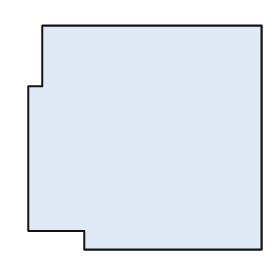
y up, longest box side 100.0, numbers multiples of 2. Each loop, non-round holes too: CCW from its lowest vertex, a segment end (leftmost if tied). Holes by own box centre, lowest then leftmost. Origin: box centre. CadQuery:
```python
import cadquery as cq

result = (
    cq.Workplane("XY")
    .moveTo(-26.0, -48.0)
    .lineTo(50.0, -48.0)
    .lineTo(50.0, 48.0)
    .lineTo(-44.0, 48.0)
    .lineTo(-44.0, 22.0)
    .lineTo(-50.0, 22.0)
    .lineTo(-50.0, -40.0)
    .lineTo(-26.0, -40.0)
    .close()
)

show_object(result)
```